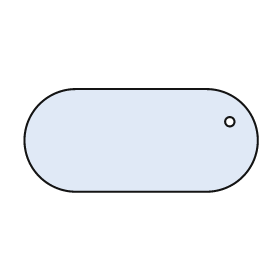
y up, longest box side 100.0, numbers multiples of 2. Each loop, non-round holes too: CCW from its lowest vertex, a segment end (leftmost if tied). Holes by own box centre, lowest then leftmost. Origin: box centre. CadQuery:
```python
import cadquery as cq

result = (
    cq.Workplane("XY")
    .moveTo(-28.0, -22.0)
    .lineTo(28.0, -22.0)
    .threePointArc((50.0, 0.0), (28.0, 22.0))
    .lineTo(-28.0, 22.0)
    .threePointArc((-50.0, 0.0), (-28.0, -22.0))
    .close()
    .moveTo(38.0, 8.0)
    .circle(2.0)
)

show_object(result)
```